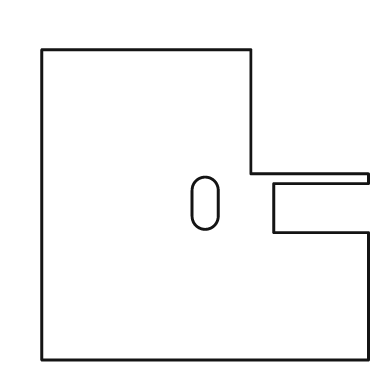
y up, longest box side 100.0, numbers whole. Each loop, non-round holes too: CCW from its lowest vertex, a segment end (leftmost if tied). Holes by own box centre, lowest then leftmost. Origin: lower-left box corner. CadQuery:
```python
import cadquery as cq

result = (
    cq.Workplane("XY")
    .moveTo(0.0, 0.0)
    .lineTo(100.0, 0.0)
    .lineTo(100.0, 39.0)
    .lineTo(71.0, 39.0)
    .lineTo(71.0, 54.0)
    .lineTo(100.0, 54.0)
    .lineTo(100.0, 57.0)
    .lineTo(64.0, 57.0)
    .lineTo(64.0, 95.0)
    .lineTo(0.0, 95.0)
    .close()
    .moveTo(46.0, 44.0)
    .threePointArc((50.0, 40.0), (54.0, 44.0))
    .lineTo(54.0, 52.0)
    .threePointArc((50.0, 56.0), (46.0, 52.0))
    .close()
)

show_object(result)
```